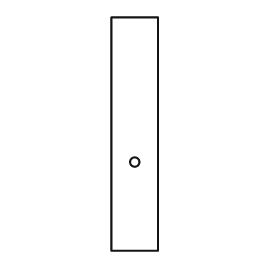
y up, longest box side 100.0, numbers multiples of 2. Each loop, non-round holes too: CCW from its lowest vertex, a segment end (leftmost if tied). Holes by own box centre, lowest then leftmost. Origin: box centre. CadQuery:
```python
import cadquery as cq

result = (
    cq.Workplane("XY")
    .moveTo(-10.0, -50.0)
    .lineTo(10.0, -50.0)
    .lineTo(10.0, 50.0)
    .lineTo(-10.0, 50.0)
    .close()
    .moveTo(0.0, -12.0)
    .circle(2.0)
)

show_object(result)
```